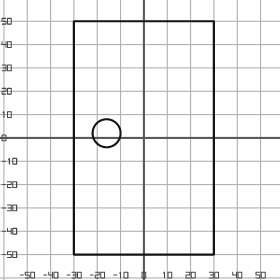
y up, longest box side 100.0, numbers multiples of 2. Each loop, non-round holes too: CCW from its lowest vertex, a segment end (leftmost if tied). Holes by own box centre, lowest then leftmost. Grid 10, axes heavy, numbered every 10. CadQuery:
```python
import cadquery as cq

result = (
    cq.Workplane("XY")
    .moveTo(-30.0, -50.0)
    .lineTo(30.0, -50.0)
    .lineTo(30.0, 50.0)
    .lineTo(-30.0, 50.0)
    .close()
    .moveTo(-16.0, 2.0)
    .circle(6.0)
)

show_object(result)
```